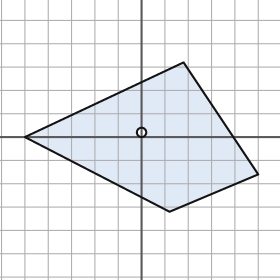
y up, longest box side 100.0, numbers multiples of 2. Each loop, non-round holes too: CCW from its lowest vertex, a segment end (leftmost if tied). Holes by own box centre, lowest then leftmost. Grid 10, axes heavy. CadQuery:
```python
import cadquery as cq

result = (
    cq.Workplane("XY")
    .moveTo(12.0, -32.0)
    .lineTo(50.0, -16.0)
    .lineTo(18.0, 32.0)
    .lineTo(-50.0, 0.0)
    .close()
    .moveTo(0.0, 2.0)
    .circle(2.0)
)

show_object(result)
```